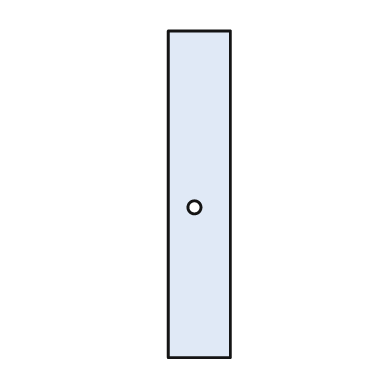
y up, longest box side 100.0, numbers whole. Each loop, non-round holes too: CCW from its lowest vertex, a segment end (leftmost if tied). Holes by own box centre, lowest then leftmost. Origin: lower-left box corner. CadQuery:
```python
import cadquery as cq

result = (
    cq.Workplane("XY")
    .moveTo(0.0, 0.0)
    .lineTo(19.0, 0.0)
    .lineTo(19.0, 100.0)
    .lineTo(0.0, 100.0)
    .close()
    .moveTo(8.0, 46.0)
    .circle(2.0)
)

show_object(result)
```